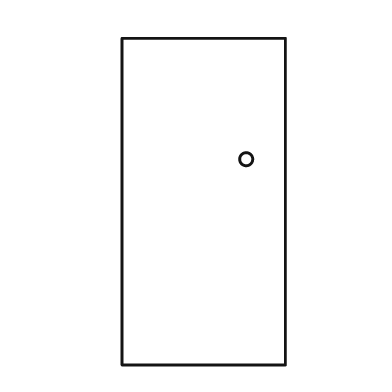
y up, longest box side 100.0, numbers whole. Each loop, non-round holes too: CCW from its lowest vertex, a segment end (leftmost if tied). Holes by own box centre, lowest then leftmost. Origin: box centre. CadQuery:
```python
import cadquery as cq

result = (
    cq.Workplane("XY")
    .moveTo(-25.0, -50.0)
    .lineTo(25.0, -50.0)
    .lineTo(25.0, 50.0)
    .lineTo(-25.0, 50.0)
    .close()
    .moveTo(13.0, 13.0)
    .circle(2.0)
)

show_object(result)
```